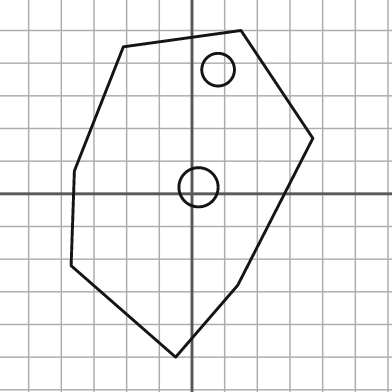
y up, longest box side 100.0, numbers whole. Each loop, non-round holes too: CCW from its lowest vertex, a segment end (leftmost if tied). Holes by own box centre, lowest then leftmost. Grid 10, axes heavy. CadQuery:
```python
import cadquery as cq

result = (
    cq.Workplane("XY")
    .moveTo(-5.0, -50.0)
    .lineTo(14.0, -28.0)
    .lineTo(37.0, 17.0)
    .lineTo(15.0, 50.0)
    .lineTo(-21.0, 45.0)
    .lineTo(-36.0, 7.0)
    .lineTo(-37.0, -22.0)
    .close()
    .moveTo(2.0, 2.0)
    .circle(6.0)
    .moveTo(8.0, 38.0)
    .circle(5.0)
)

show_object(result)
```